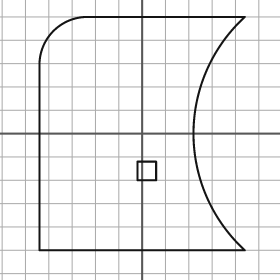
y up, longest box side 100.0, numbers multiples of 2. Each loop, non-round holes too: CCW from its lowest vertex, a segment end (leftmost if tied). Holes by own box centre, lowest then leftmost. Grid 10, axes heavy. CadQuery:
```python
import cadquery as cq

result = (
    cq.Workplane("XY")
    .moveTo(-44.0, -50.0)
    .lineTo(44.0, -50.0)
    .threePointArc((22.0, 0.0), (44.0, 50.0))
    .lineTo(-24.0, 50.0)
    .threePointArc((-38.0, 44.0), (-44.0, 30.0))
    .close()
    .moveTo(-2.0, -20.0)
    .lineTo(6.0, -20.0)
    .lineTo(6.0, -12.0)
    .lineTo(-2.0, -12.0)
    .close()
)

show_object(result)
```